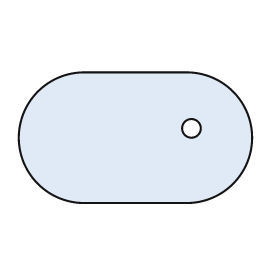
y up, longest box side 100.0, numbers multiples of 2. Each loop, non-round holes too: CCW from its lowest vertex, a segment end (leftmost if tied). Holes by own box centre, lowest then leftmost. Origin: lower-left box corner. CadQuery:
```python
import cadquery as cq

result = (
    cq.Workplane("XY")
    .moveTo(28.0, 0.0)
    .lineTo(72.0, 0.0)
    .threePointArc((100.0, 28.0), (72.0, 56.0))
    .lineTo(28.0, 56.0)
    .threePointArc((0.0, 28.0), (28.0, 0.0))
    .close()
    .moveTo(74.0, 32.0)
    .circle(4.0)
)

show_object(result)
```